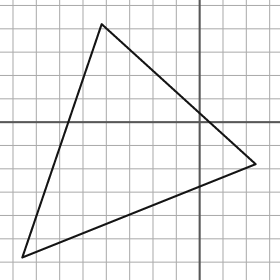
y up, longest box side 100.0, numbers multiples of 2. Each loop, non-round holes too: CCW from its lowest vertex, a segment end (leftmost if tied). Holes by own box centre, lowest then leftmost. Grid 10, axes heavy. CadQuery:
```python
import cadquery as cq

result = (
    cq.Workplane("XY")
    .moveTo(-76.0, -58.0)
    .lineTo(24.0, -18.0)
    .lineTo(-42.0, 42.0)
    .close()
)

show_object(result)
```